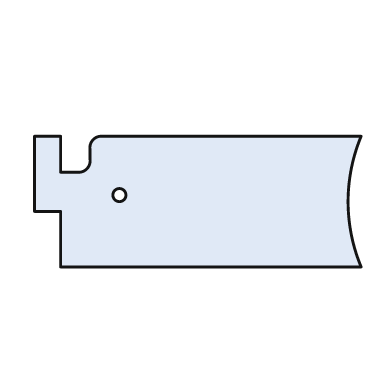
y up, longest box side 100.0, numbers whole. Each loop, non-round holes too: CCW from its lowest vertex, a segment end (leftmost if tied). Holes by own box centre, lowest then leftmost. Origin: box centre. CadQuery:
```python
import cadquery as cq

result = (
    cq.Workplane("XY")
    .moveTo(-42.0, -20.0)
    .lineTo(50.0, -20.0)
    .threePointArc((46.0, 0.0), (50.0, 20.0))
    .lineTo(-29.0, 20.0)
    .threePointArc((-32.0, 19.0), (-33.0, 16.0))
    .lineTo(-33.0, 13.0)
    .threePointArc((-34.0, 10.0), (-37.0, 9.0))
    .lineTo(-42.0, 9.0)
    .lineTo(-42.0, 20.0)
    .lineTo(-50.0, 20.0)
    .lineTo(-50.0, -3.0)
    .lineTo(-42.0, -3.0)
    .close()
    .moveTo(-24.0, 2.0)
    .circle(2.0)
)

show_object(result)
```